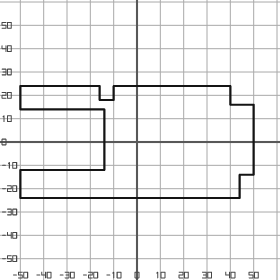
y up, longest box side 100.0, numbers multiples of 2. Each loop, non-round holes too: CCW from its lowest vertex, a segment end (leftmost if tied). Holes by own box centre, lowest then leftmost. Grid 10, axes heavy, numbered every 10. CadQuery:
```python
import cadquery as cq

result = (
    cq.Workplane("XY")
    .moveTo(-50.0, -24.0)
    .lineTo(44.0, -24.0)
    .lineTo(44.0, -14.0)
    .lineTo(50.0, -14.0)
    .lineTo(50.0, 16.0)
    .lineTo(40.0, 16.0)
    .lineTo(40.0, 24.0)
    .lineTo(-10.0, 24.0)
    .lineTo(-10.0, 18.0)
    .lineTo(-16.0, 18.0)
    .lineTo(-16.0, 24.0)
    .lineTo(-50.0, 24.0)
    .lineTo(-50.0, 14.0)
    .lineTo(-14.0, 14.0)
    .lineTo(-14.0, -12.0)
    .lineTo(-50.0, -12.0)
    .close()
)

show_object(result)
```